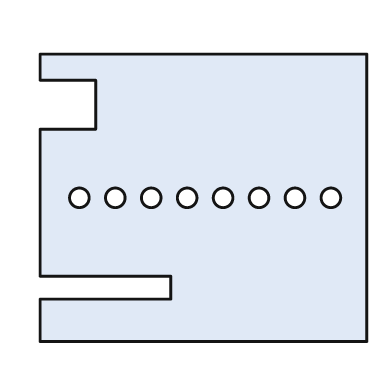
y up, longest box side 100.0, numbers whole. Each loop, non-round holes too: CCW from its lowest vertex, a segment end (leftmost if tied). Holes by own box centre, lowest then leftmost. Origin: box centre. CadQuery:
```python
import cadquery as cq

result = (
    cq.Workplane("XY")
    .moveTo(-50.0, -44.0)
    .lineTo(50.0, -44.0)
    .lineTo(50.0, 44.0)
    .lineTo(-50.0, 44.0)
    .lineTo(-50.0, 36.0)
    .lineTo(-33.0, 36.0)
    .lineTo(-33.0, 21.0)
    .lineTo(-50.0, 21.0)
    .lineTo(-50.0, -24.0)
    .lineTo(-10.0, -24.0)
    .lineTo(-10.0, -31.0)
    .lineTo(-50.0, -31.0)
    .close()
    .moveTo(-38.0, 0.0)
    .circle(3.0)
    .moveTo(-27.0, 0.0)
    .circle(3.0)
    .moveTo(-16.0, 0.0)
    .circle(3.0)
    .moveTo(-5.0, 0.0)
    .circle(3.0)
    .moveTo(6.0, 0.0)
    .circle(3.0)
    .moveTo(17.0, 0.0)
    .circle(3.0)
    .moveTo(28.0, 0.0)
    .circle(3.0)
    .moveTo(39.0, 0.0)
    .circle(3.0)
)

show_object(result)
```